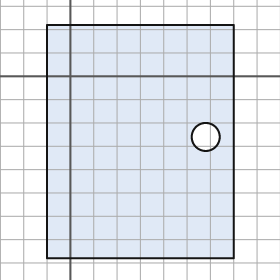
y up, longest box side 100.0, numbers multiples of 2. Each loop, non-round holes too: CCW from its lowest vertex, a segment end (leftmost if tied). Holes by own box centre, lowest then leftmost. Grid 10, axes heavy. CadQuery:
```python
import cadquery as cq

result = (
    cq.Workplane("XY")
    .moveTo(-10.0, -78.0)
    .lineTo(70.0, -78.0)
    .lineTo(70.0, 22.0)
    .lineTo(-10.0, 22.0)
    .close()
    .moveTo(58.0, -26.0)
    .circle(6.0)
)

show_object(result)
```